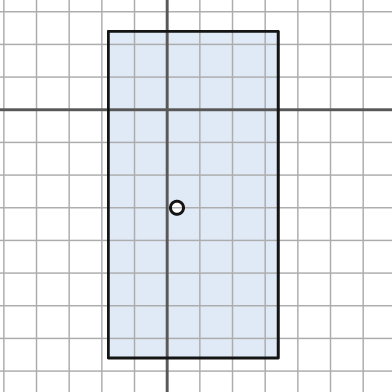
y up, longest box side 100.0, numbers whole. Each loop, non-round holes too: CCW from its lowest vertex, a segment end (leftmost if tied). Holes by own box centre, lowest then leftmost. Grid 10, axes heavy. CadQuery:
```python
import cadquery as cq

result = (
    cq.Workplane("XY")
    .moveTo(-18.0, -76.0)
    .lineTo(34.0, -76.0)
    .lineTo(34.0, 24.0)
    .lineTo(-18.0, 24.0)
    .close()
    .moveTo(3.0, -30.0)
    .circle(2.0)
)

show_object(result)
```